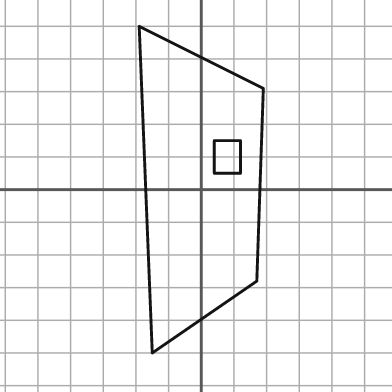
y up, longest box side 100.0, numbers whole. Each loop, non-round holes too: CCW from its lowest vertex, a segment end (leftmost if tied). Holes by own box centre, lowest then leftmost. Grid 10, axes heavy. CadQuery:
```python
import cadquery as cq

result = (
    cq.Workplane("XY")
    .moveTo(-15.0, -50.0)
    .lineTo(17.0, -28.0)
    .lineTo(19.0, 31.0)
    .lineTo(-19.0, 50.0)
    .close()
    .moveTo(4.0, 5.0)
    .lineTo(12.0, 5.0)
    .lineTo(12.0, 15.0)
    .lineTo(4.0, 15.0)
    .close()
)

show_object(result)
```